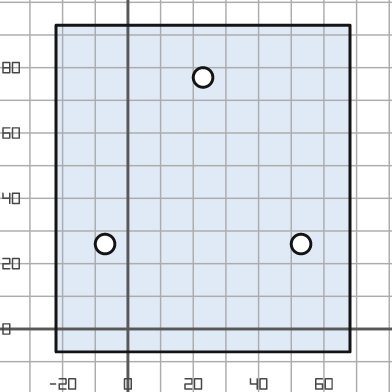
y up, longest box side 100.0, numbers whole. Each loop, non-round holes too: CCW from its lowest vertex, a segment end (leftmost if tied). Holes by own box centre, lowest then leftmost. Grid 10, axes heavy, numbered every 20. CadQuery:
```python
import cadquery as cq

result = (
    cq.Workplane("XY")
    .moveTo(-22.0, -7.0)
    .lineTo(68.0, -7.0)
    .lineTo(68.0, 93.0)
    .lineTo(-22.0, 93.0)
    .close()
    .moveTo(-7.0, 26.0)
    .circle(3.0)
    .moveTo(53.0, 26.0)
    .circle(3.0)
    .moveTo(23.0, 77.0)
    .circle(3.0)
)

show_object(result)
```